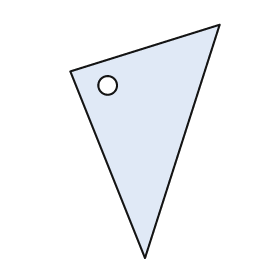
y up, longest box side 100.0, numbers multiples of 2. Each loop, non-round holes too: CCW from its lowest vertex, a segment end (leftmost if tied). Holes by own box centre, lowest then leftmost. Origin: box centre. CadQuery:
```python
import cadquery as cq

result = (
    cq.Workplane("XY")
    .moveTo(0.0, -50.0)
    .lineTo(32.0, 50.0)
    .lineTo(-32.0, 30.0)
    .close()
    .moveTo(-16.0, 24.0)
    .circle(4.0)
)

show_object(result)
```